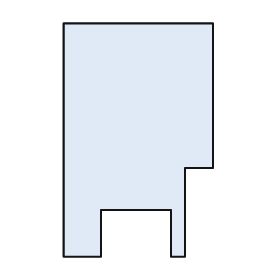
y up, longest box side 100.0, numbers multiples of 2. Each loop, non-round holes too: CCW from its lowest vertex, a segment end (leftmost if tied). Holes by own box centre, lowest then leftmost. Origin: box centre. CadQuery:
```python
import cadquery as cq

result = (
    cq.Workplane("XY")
    .moveTo(-32.0, -50.0)
    .lineTo(-16.0, -50.0)
    .lineTo(-16.0, -30.0)
    .lineTo(14.0, -30.0)
    .lineTo(14.0, -50.0)
    .lineTo(20.0, -50.0)
    .lineTo(20.0, -12.0)
    .lineTo(32.0, -12.0)
    .lineTo(32.0, 50.0)
    .lineTo(-32.0, 50.0)
    .close()
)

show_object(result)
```